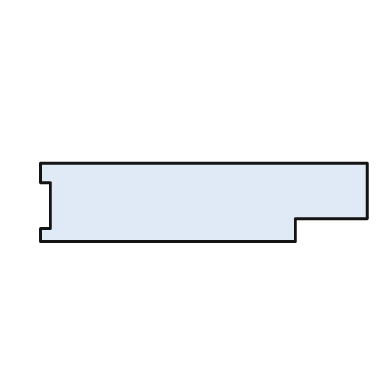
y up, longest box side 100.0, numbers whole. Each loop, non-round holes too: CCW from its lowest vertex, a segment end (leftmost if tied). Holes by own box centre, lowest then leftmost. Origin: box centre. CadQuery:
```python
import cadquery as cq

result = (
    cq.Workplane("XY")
    .moveTo(-50.0, -12.0)
    .lineTo(28.0, -12.0)
    .lineTo(28.0, -5.0)
    .lineTo(50.0, -5.0)
    .lineTo(50.0, 12.0)
    .lineTo(-50.0, 12.0)
    .lineTo(-50.0, 6.0)
    .lineTo(-47.0, 6.0)
    .lineTo(-47.0, -8.0)
    .lineTo(-50.0, -8.0)
    .close()
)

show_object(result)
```